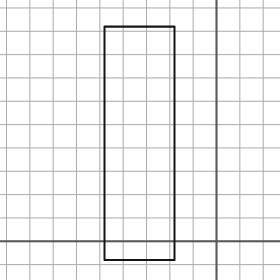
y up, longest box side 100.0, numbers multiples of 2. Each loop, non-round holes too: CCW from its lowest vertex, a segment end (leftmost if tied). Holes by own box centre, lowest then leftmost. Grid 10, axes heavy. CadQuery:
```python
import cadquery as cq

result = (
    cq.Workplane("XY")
    .moveTo(-48.0, -8.0)
    .lineTo(-18.0, -8.0)
    .lineTo(-18.0, 92.0)
    .lineTo(-48.0, 92.0)
    .close()
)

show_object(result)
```